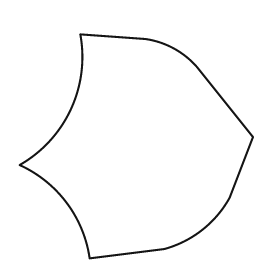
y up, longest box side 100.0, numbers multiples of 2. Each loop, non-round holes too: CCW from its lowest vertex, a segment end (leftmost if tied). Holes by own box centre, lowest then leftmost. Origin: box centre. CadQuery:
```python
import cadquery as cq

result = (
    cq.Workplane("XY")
    .moveTo(-20.0, -48.0)
    .lineTo(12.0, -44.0)
    .threePointArc((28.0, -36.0), (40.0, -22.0))
    .lineTo(50.0, 4.0)
    .lineTo(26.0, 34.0)
    .threePointArc((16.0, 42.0), (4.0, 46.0))
    .lineTo(-24.0, 48.0)
    .threePointArc((-28.0, 16.0), (-50.0, -8.0))
    .threePointArc((-30.0, -24.0), (-20.0, -48.0))
    .close()
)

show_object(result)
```